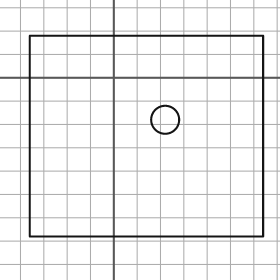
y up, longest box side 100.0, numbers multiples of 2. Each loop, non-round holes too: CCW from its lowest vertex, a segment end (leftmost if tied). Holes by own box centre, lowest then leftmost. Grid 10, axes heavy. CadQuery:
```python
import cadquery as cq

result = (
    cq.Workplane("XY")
    .moveTo(-36.0, -68.0)
    .lineTo(64.0, -68.0)
    .lineTo(64.0, 18.0)
    .lineTo(-36.0, 18.0)
    .close()
    .moveTo(22.0, -18.0)
    .circle(6.0)
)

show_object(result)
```